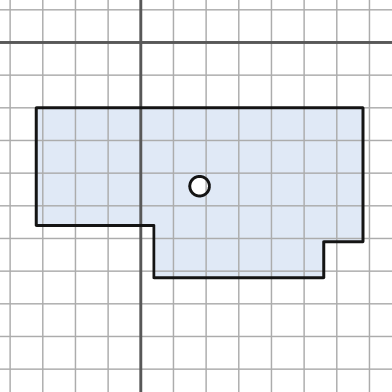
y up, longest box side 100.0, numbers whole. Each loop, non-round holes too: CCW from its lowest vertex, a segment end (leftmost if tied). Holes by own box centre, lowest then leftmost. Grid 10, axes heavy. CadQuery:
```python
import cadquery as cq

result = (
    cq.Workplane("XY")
    .moveTo(4.0, -72.0)
    .lineTo(56.0, -72.0)
    .lineTo(56.0, -61.0)
    .lineTo(68.0, -61.0)
    .lineTo(68.0, -20.0)
    .lineTo(-32.0, -20.0)
    .lineTo(-32.0, -56.0)
    .lineTo(4.0, -56.0)
    .close()
    .moveTo(18.0, -44.0)
    .circle(3.0)
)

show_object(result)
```